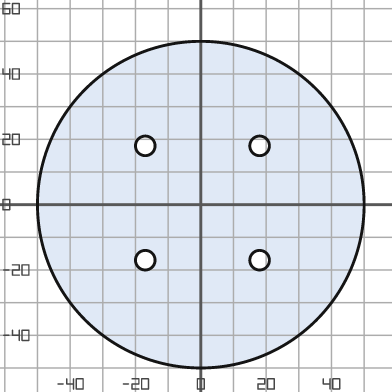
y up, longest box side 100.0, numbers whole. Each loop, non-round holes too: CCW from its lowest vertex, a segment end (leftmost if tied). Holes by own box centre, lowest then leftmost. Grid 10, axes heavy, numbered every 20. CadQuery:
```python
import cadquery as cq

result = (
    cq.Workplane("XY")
    .moveTo(0.0, 0.0)
    .circle(50.0)
    .moveTo(-17.0, -17.0)
    .circle(3.0)
    .moveTo(18.0, -17.0)
    .circle(3.0)
    .moveTo(-17.0, 18.0)
    .circle(3.0)
    .moveTo(18.0, 18.0)
    .circle(3.0)
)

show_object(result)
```